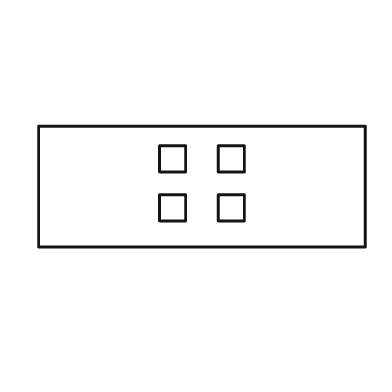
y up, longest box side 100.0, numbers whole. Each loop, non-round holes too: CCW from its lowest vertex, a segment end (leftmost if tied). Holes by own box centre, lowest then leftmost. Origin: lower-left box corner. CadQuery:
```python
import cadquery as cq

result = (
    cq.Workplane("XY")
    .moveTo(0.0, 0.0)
    .lineTo(100.0, 0.0)
    .lineTo(100.0, 37.0)
    .lineTo(0.0, 37.0)
    .close()
    .moveTo(37.0, 8.0)
    .lineTo(45.0, 8.0)
    .lineTo(45.0, 16.0)
    .lineTo(37.0, 16.0)
    .close()
    .moveTo(55.0, 8.0)
    .lineTo(63.0, 8.0)
    .lineTo(63.0, 16.0)
    .lineTo(55.0, 16.0)
    .close()
    .moveTo(37.0, 23.0)
    .lineTo(45.0, 23.0)
    .lineTo(45.0, 31.0)
    .lineTo(37.0, 31.0)
    .close()
    .moveTo(55.0, 23.0)
    .lineTo(63.0, 23.0)
    .lineTo(63.0, 31.0)
    .lineTo(55.0, 31.0)
    .close()
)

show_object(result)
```